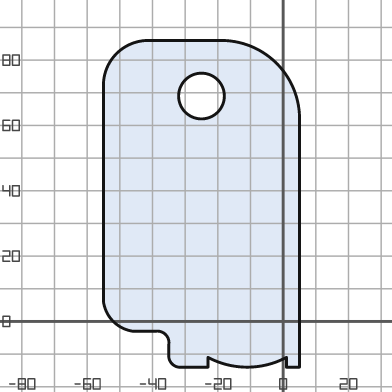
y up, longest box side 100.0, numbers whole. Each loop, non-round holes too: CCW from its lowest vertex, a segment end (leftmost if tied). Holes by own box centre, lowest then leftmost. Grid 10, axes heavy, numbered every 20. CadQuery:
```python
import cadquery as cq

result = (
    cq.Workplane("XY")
    .moveTo(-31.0, -14.0)
    .lineTo(-23.0, -14.0)
    .lineTo(-23.0, -11.0)
    .threePointArc((-11.0, -14.0), (1.0, -11.0))
    .lineTo(1.0, -14.0)
    .lineTo(5.0, -14.0)
    .lineTo(5.0, 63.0)
    .threePointArc((-2.0, 79.0), (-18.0, 86.0))
    .lineTo(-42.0, 86.0)
    .threePointArc((-51.0, 82.0), (-55.0, 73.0))
    .lineTo(-55.0, 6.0)
    .threePointArc((-52.0, 0.0), (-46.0, -3.0))
    .lineTo(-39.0, -3.0)
    .threePointArc((-36.0, -4.0), (-35.0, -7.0))
    .lineTo(-35.0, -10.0)
    .threePointArc((-34.0, -13.0), (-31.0, -14.0))
    .close()
    .moveTo(-25.0, 69.0)
    .circle(7.0)
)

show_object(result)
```